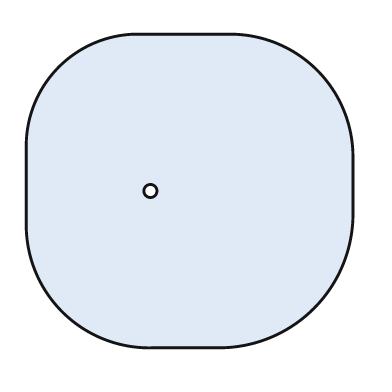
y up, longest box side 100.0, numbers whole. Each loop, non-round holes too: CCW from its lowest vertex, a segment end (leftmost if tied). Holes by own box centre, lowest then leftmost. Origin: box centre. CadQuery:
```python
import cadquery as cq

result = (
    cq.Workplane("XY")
    .moveTo(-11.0, -48.0)
    .lineTo(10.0, -48.0)
    .threePointArc((38.0, -36.0), (50.0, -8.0))
    .lineTo(50.0, 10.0)
    .threePointArc((39.0, 37.0), (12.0, 48.0))
    .lineTo(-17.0, 48.0)
    .threePointArc((-40.0, 38.0), (-50.0, 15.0))
    .lineTo(-50.0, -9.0)
    .threePointArc((-39.0, -37.0), (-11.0, -48.0))
    .close()
    .moveTo(-12.0, 0.0)
    .circle(2.0)
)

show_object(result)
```